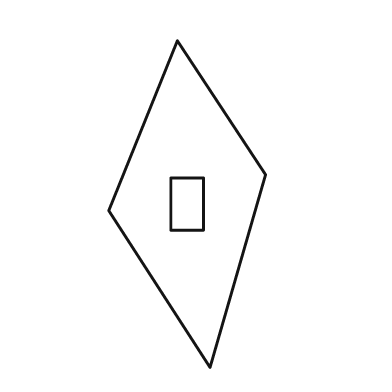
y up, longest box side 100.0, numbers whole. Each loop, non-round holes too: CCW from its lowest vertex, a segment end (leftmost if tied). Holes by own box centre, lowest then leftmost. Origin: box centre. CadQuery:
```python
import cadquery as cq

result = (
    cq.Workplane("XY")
    .moveTo(7.0, -50.0)
    .lineTo(24.0, 9.0)
    .lineTo(-3.0, 50.0)
    .lineTo(-24.0, -2.0)
    .close()
    .moveTo(-5.0, -8.0)
    .lineTo(5.0, -8.0)
    .lineTo(5.0, 8.0)
    .lineTo(-5.0, 8.0)
    .close()
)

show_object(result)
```